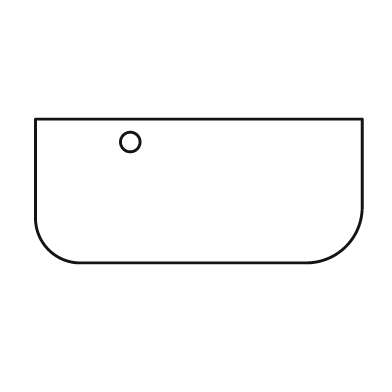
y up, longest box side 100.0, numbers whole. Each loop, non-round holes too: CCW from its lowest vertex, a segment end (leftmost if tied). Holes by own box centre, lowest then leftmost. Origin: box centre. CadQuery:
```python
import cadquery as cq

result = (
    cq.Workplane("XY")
    .moveTo(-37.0, -22.0)
    .lineTo(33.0, -22.0)
    .threePointArc((45.0, -17.0), (50.0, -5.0))
    .lineTo(50.0, 22.0)
    .lineTo(-50.0, 22.0)
    .lineTo(-50.0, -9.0)
    .threePointArc((-46.0, -18.0), (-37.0, -22.0))
    .close()
    .moveTo(-21.0, 15.0)
    .circle(3.0)
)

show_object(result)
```